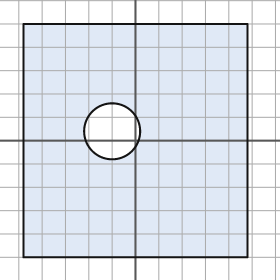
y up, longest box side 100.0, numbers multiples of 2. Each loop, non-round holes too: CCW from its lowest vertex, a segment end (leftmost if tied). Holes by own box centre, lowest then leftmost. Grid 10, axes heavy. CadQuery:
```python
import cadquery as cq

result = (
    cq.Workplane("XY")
    .moveTo(-48.0, -50.0)
    .lineTo(48.0, -50.0)
    .lineTo(48.0, 50.0)
    .lineTo(-48.0, 50.0)
    .close()
    .moveTo(-10.0, 4.0)
    .circle(12.0)
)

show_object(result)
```